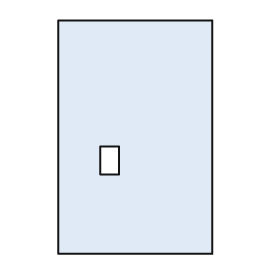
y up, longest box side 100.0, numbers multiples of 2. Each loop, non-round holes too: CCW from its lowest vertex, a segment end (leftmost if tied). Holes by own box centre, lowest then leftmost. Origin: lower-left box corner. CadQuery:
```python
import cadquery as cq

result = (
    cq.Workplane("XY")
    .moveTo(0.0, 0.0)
    .lineTo(66.0, 0.0)
    .lineTo(66.0, 100.0)
    .lineTo(0.0, 100.0)
    .close()
    .moveTo(18.0, 34.0)
    .lineTo(26.0, 34.0)
    .lineTo(26.0, 46.0)
    .lineTo(18.0, 46.0)
    .close()
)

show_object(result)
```